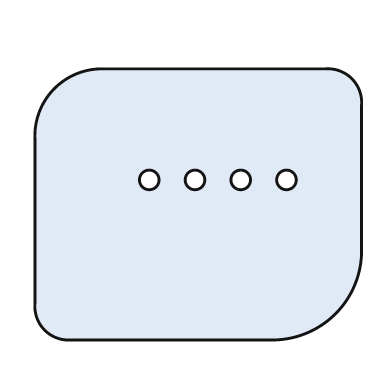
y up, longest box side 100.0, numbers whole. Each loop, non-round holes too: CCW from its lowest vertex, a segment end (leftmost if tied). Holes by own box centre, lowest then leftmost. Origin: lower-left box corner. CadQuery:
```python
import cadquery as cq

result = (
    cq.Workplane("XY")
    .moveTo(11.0, 0.0)
    .lineTo(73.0, 0.0)
    .threePointArc((92.0, 8.0), (100.0, 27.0))
    .lineTo(100.0, 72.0)
    .threePointArc((97.0, 80.0), (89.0, 83.0))
    .lineTo(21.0, 83.0)
    .threePointArc((6.0, 77.0), (0.0, 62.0))
    .lineTo(0.0, 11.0)
    .threePointArc((3.0, 3.0), (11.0, 0.0))
    .close()
    .moveTo(35.0, 49.0)
    .circle(3.0)
    .moveTo(49.0, 49.0)
    .circle(3.0)
    .moveTo(63.0, 49.0)
    .circle(3.0)
    .moveTo(77.0, 49.0)
    .circle(3.0)
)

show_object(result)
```